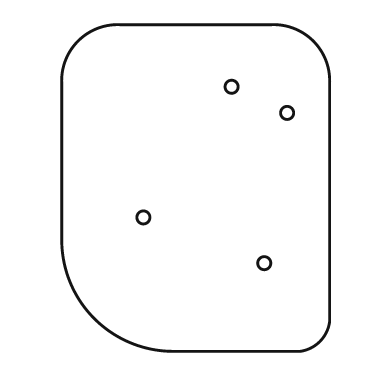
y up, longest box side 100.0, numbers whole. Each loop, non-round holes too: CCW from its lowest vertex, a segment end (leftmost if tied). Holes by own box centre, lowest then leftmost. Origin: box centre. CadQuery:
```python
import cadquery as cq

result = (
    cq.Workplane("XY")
    .moveTo(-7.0, -50.0)
    .lineTo(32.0, -50.0)
    .threePointArc((38.0, -47.0), (41.0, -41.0))
    .lineTo(41.0, 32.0)
    .threePointArc((36.0, 45.0), (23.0, 50.0))
    .lineTo(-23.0, 50.0)
    .threePointArc((-36.0, 45.0), (-41.0, 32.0))
    .lineTo(-41.0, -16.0)
    .threePointArc((-31.0, -40.0), (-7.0, -50.0))
    .close()
    .moveTo(21.0, -23.0)
    .circle(2.0)
    .moveTo(-16.0, -9.0)
    .circle(2.0)
    .moveTo(28.0, 23.0)
    .circle(2.0)
    .moveTo(11.0, 31.0)
    .circle(2.0)
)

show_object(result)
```